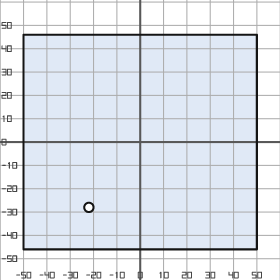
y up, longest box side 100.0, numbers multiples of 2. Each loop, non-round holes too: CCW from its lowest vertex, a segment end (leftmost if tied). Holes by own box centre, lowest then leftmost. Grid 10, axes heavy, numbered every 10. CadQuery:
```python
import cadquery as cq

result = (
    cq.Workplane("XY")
    .moveTo(-50.0, -46.0)
    .lineTo(50.0, -46.0)
    .lineTo(50.0, 46.0)
    .lineTo(-50.0, 46.0)
    .close()
    .moveTo(-22.0, -28.0)
    .circle(2.0)
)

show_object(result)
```